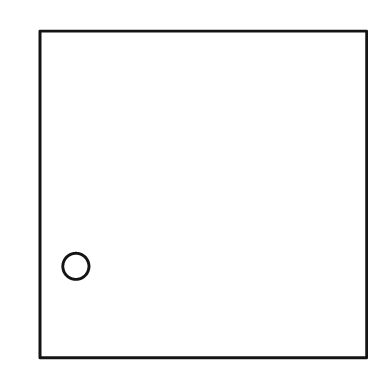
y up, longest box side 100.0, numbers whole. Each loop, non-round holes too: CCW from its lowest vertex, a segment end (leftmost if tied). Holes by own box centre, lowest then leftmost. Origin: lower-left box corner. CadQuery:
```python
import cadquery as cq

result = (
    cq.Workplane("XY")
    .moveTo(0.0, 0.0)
    .lineTo(100.0, 0.0)
    .lineTo(100.0, 100.0)
    .lineTo(0.0, 100.0)
    .close()
    .moveTo(11.0, 28.0)
    .circle(4.0)
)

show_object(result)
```